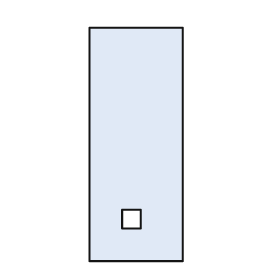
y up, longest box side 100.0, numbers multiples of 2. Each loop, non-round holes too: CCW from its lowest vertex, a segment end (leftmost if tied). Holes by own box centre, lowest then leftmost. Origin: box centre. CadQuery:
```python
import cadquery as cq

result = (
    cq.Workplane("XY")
    .moveTo(-20.0, -50.0)
    .lineTo(20.0, -50.0)
    .lineTo(20.0, 50.0)
    .lineTo(-20.0, 50.0)
    .close()
    .moveTo(-6.0, -36.0)
    .lineTo(2.0, -36.0)
    .lineTo(2.0, -28.0)
    .lineTo(-6.0, -28.0)
    .close()
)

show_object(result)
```